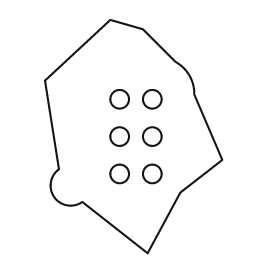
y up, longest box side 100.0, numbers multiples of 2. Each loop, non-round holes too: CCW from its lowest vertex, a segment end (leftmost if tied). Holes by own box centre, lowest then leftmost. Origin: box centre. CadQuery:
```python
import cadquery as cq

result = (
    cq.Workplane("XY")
    .moveTo(6.0, -50.0)
    .lineTo(20.0, -24.0)
    .lineTo(38.0, -10.0)
    .lineTo(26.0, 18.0)
    .threePointArc((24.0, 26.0), (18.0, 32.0))
    .lineTo(4.0, 46.0)
    .lineTo(-10.0, 50.0)
    .lineTo(-38.0, 24.0)
    .lineTo(-32.0, -14.0)
    .threePointArc((-34.0, -26.0), (-22.0, -28.0))
    .close()
    .moveTo(-6.0, -16.0)
    .circle(4.0)
    .moveTo(8.0, -16.0)
    .circle(4.0)
    .moveTo(-6.0, 0.0)
    .circle(4.0)
    .moveTo(8.0, 0.0)
    .circle(4.0)
    .moveTo(-6.0, 16.0)
    .circle(4.0)
    .moveTo(8.0, 16.0)
    .circle(4.0)
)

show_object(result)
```